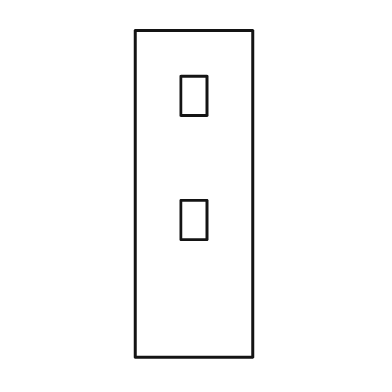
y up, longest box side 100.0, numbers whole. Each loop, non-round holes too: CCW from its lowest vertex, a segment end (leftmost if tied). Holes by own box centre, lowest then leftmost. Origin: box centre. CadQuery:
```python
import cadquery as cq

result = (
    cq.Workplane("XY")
    .moveTo(-18.0, -50.0)
    .lineTo(18.0, -50.0)
    .lineTo(18.0, 50.0)
    .lineTo(-18.0, 50.0)
    .close()
    .moveTo(-4.0, -14.0)
    .lineTo(4.0, -14.0)
    .lineTo(4.0, -2.0)
    .lineTo(-4.0, -2.0)
    .close()
    .moveTo(-4.0, 24.0)
    .lineTo(4.0, 24.0)
    .lineTo(4.0, 36.0)
    .lineTo(-4.0, 36.0)
    .close()
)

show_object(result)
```